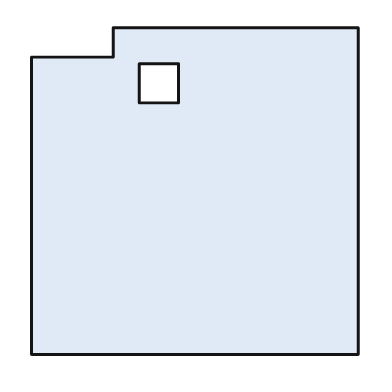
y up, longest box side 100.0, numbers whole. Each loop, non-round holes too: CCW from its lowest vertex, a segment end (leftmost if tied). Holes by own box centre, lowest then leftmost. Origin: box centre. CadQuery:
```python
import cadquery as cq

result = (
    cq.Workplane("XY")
    .moveTo(-50.0, -50.0)
    .lineTo(50.0, -50.0)
    .lineTo(50.0, 50.0)
    .lineTo(-25.0, 50.0)
    .lineTo(-25.0, 41.0)
    .lineTo(-50.0, 41.0)
    .close()
    .moveTo(-17.0, 27.0)
    .lineTo(-5.0, 27.0)
    .lineTo(-5.0, 39.0)
    .lineTo(-17.0, 39.0)
    .close()
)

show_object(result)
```